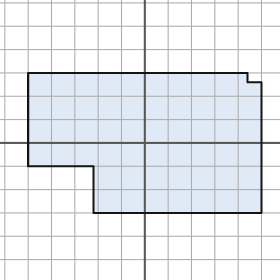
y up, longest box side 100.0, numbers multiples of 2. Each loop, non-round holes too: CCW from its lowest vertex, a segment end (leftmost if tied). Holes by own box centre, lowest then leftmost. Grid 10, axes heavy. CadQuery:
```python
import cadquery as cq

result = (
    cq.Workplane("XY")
    .moveTo(-22.0, -30.0)
    .lineTo(50.0, -30.0)
    .lineTo(50.0, 26.0)
    .lineTo(44.0, 26.0)
    .lineTo(44.0, 30.0)
    .lineTo(-50.0, 30.0)
    .lineTo(-50.0, -10.0)
    .lineTo(-22.0, -10.0)
    .close()
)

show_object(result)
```